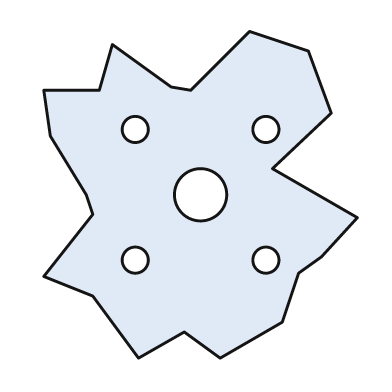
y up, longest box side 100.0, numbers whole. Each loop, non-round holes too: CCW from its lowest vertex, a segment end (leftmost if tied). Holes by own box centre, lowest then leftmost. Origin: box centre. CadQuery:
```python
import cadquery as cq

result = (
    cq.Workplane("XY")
    .moveTo(-19.0, -50.0)
    .lineTo(-5.0, -42.0)
    .lineTo(6.0, -50.0)
    .lineTo(25.0, -39.0)
    .lineTo(30.0, -24.0)
    .lineTo(37.0, -19.0)
    .lineTo(48.0, -7.0)
    .lineTo(22.0, 8.0)
    .lineTo(40.0, 25.0)
    .lineTo(33.0, 44.0)
    .lineTo(15.0, 50.0)
    .lineTo(-3.0, 32.0)
    .lineTo(-9.0, 33.0)
    .lineTo(-27.0, 46.0)
    .lineTo(-31.0, 32.0)
    .lineTo(-48.0, 32.0)
    .lineTo(-46.0, 18.0)
    .lineTo(-35.0, 0.0)
    .lineTo(-33.0, -6.0)
    .lineTo(-48.0, -25.0)
    .lineTo(-33.0, -31.0)
    .close()
    .moveTo(-20.0, -20.0)
    .circle(4.0)
    .moveTo(20.0, -20.0)
    .circle(4.0)
    .moveTo(0.0, 0.0)
    .circle(8.0)
    .moveTo(-20.0, 20.0)
    .circle(4.0)
    .moveTo(20.0, 20.0)
    .circle(4.0)
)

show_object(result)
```